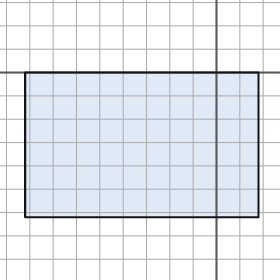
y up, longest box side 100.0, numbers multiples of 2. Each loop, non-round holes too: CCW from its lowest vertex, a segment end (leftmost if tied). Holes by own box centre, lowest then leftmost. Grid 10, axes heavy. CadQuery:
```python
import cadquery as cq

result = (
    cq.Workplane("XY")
    .moveTo(-82.0, -62.0)
    .lineTo(18.0, -62.0)
    .lineTo(18.0, 0.0)
    .lineTo(-82.0, 0.0)
    .close()
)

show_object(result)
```